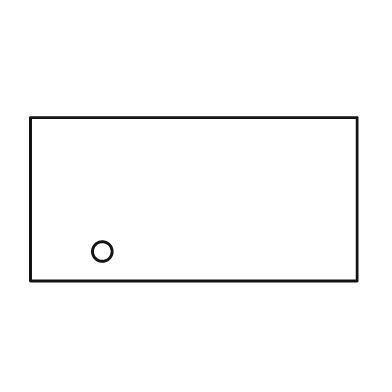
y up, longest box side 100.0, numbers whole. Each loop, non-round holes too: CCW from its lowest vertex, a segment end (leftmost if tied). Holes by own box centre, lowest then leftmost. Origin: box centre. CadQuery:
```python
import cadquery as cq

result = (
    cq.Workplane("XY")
    .moveTo(-50.0, -25.0)
    .lineTo(50.0, -25.0)
    .lineTo(50.0, 25.0)
    .lineTo(-50.0, 25.0)
    .close()
    .moveTo(-28.0, -16.0)
    .circle(3.0)
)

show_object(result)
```